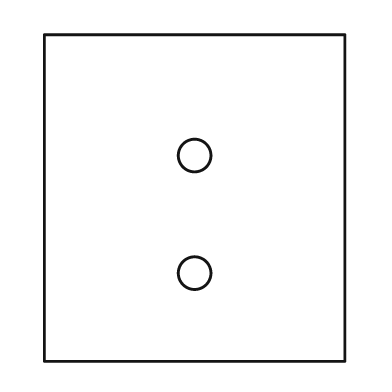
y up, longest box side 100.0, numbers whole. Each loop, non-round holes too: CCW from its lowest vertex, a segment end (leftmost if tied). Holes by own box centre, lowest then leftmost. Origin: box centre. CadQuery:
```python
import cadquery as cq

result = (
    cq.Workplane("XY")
    .moveTo(-46.0, -50.0)
    .lineTo(46.0, -50.0)
    .lineTo(46.0, 50.0)
    .lineTo(-46.0, 50.0)
    .close()
    .moveTo(0.0, -23.0)
    .circle(5.0)
    .moveTo(0.0, 13.0)
    .circle(5.0)
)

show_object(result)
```